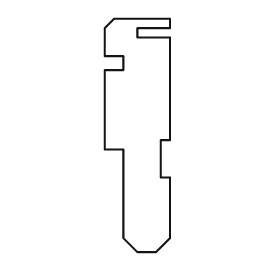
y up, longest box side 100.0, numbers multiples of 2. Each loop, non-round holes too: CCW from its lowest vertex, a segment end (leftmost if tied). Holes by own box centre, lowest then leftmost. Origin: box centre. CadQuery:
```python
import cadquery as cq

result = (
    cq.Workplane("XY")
    .moveTo(0.0, -50.0)
    .lineTo(8.0, -50.0)
    .lineTo(14.0, -44.0)
    .lineTo(14.0, -18.0)
    .lineTo(10.0, -18.0)
    .lineTo(10.0, -2.0)
    .lineTo(14.0, -2.0)
    .lineTo(14.0, 42.0)
    .lineTo(0.0, 42.0)
    .lineTo(0.0, 46.0)
    .lineTo(14.0, 46.0)
    .lineTo(14.0, 50.0)
    .lineTo(-10.0, 50.0)
    .lineTo(-14.0, 46.0)
    .lineTo(-14.0, 34.0)
    .lineTo(-6.0, 34.0)
    .lineTo(-6.0, 28.0)
    .lineTo(-14.0, 28.0)
    .lineTo(-14.0, -6.0)
    .lineTo(-6.0, -6.0)
    .lineTo(-6.0, -44.0)
    .close()
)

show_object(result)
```